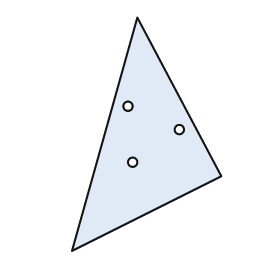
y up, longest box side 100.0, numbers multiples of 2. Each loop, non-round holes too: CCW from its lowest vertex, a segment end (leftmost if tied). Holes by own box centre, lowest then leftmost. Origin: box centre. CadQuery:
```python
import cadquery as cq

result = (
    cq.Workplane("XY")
    .moveTo(-32.0, -50.0)
    .lineTo(32.0, -18.0)
    .lineTo(-4.0, 50.0)
    .close()
    .moveTo(-6.0, -12.0)
    .circle(2.0)
    .moveTo(14.0, 2.0)
    .circle(2.0)
    .moveTo(-8.0, 12.0)
    .circle(2.0)
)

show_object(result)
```